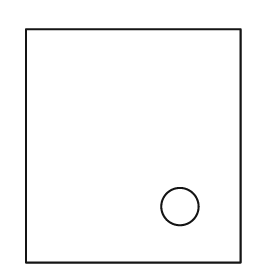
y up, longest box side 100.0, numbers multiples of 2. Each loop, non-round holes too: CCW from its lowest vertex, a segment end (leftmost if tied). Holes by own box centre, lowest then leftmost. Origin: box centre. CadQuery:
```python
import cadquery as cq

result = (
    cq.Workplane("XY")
    .moveTo(-46.0, -50.0)
    .lineTo(46.0, -50.0)
    .lineTo(46.0, 50.0)
    .lineTo(-46.0, 50.0)
    .close()
    .moveTo(20.0, -26.0)
    .circle(8.0)
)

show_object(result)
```